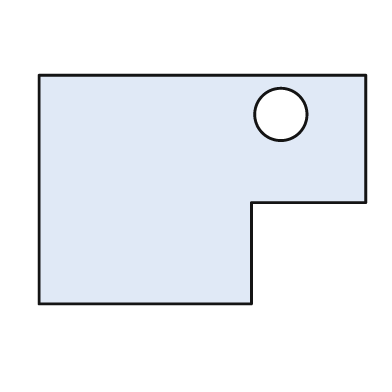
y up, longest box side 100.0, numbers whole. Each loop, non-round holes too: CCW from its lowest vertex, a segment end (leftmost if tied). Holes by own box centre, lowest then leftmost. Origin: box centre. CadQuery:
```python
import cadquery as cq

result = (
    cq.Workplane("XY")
    .moveTo(-50.0, -35.0)
    .lineTo(15.0, -35.0)
    .lineTo(15.0, -4.0)
    .lineTo(50.0, -4.0)
    .lineTo(50.0, 35.0)
    .lineTo(-50.0, 35.0)
    .close()
    .moveTo(24.0, 23.0)
    .circle(8.0)
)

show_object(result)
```